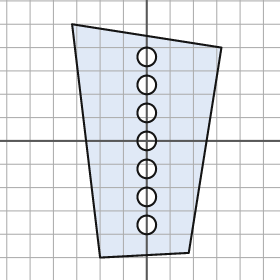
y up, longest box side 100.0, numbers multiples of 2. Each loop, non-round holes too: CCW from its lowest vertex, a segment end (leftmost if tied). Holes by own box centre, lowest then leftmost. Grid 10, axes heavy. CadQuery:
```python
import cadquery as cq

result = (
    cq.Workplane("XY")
    .moveTo(-20.0, -50.0)
    .lineTo(18.0, -48.0)
    .lineTo(32.0, 40.0)
    .lineTo(-32.0, 50.0)
    .close()
    .moveTo(0.0, -36.0)
    .circle(4.0)
    .moveTo(0.0, -24.0)
    .circle(4.0)
    .moveTo(0.0, -12.0)
    .circle(4.0)
    .moveTo(0.0, 0.0)
    .circle(4.0)
    .moveTo(0.0, 12.0)
    .circle(4.0)
    .moveTo(0.0, 24.0)
    .circle(4.0)
    .moveTo(0.0, 36.0)
    .circle(4.0)
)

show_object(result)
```